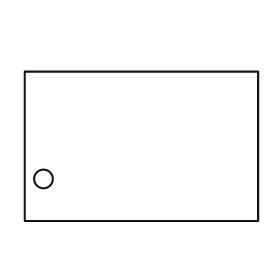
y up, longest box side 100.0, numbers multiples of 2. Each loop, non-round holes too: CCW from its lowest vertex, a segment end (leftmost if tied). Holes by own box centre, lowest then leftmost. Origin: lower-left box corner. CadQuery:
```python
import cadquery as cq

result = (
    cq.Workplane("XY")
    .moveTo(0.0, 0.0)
    .lineTo(100.0, 0.0)
    .lineTo(100.0, 64.0)
    .lineTo(0.0, 64.0)
    .close()
    .moveTo(8.0, 18.0)
    .circle(4.0)
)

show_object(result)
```